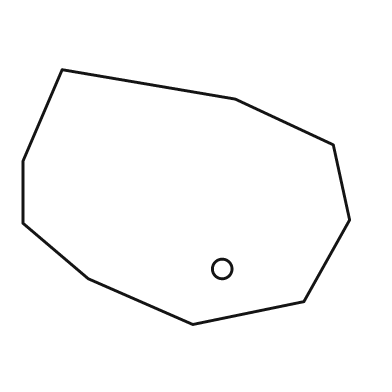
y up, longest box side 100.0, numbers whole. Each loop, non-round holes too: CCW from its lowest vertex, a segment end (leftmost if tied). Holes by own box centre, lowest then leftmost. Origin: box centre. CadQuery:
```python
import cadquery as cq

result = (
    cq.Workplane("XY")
    .moveTo(2.0, -39.0)
    .lineTo(36.0, -32.0)
    .lineTo(50.0, -7.0)
    .lineTo(45.0, 16.0)
    .lineTo(15.0, 30.0)
    .lineTo(-38.0, 39.0)
    .lineTo(-50.0, 11.0)
    .lineTo(-50.0, -8.0)
    .lineTo(-30.0, -25.0)
    .close()
    .moveTo(11.0, -22.0)
    .circle(3.0)
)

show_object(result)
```